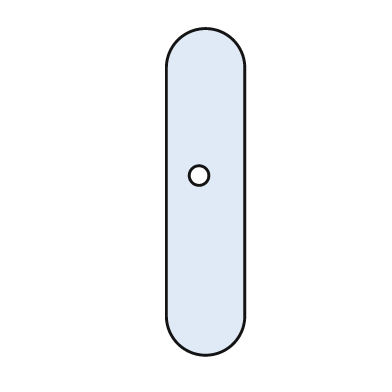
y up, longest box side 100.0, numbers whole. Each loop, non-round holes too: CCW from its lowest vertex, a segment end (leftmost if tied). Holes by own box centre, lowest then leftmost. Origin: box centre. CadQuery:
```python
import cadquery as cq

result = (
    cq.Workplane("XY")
    .moveTo(-12.0, -38.0)
    .threePointArc((0.0, -50.0), (12.0, -38.0))
    .lineTo(12.0, 38.0)
    .threePointArc((0.0, 50.0), (-12.0, 38.0))
    .close()
    .moveTo(-2.0, 5.0)
    .circle(3.0)
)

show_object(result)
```